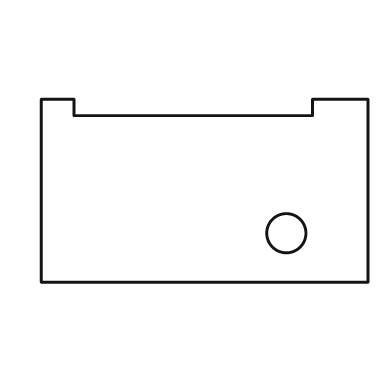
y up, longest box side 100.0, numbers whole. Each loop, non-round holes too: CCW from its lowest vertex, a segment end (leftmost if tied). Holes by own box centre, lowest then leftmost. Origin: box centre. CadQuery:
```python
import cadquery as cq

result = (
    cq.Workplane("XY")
    .moveTo(-50.0, -28.0)
    .lineTo(50.0, -28.0)
    .lineTo(50.0, 28.0)
    .lineTo(33.0, 28.0)
    .lineTo(33.0, 23.0)
    .lineTo(-40.0, 23.0)
    .lineTo(-40.0, 28.0)
    .lineTo(-50.0, 28.0)
    .close()
    .moveTo(25.0, -13.0)
    .circle(6.0)
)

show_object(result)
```